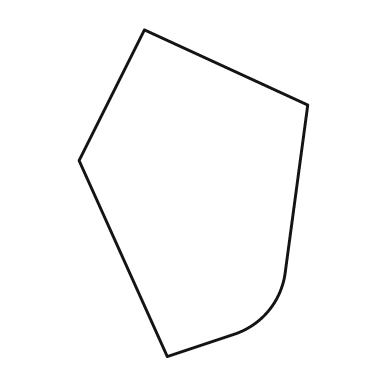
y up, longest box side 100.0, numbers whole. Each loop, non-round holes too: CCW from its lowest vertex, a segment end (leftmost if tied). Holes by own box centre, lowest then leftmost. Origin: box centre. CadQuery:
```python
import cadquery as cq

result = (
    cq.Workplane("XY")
    .moveTo(-8.0, -50.0)
    .lineTo(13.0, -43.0)
    .threePointArc((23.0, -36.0), (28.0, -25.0))
    .lineTo(35.0, 27.0)
    .lineTo(-15.0, 50.0)
    .lineTo(-35.0, 10.0)
    .close()
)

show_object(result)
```